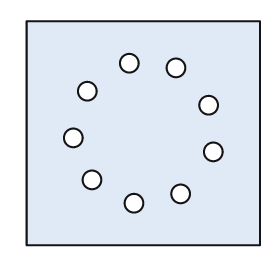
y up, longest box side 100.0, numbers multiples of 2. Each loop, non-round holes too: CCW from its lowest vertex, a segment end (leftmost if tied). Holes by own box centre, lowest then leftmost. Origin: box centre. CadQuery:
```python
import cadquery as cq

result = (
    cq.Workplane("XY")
    .moveTo(-50.0, -48.0)
    .lineTo(50.0, -48.0)
    .lineTo(50.0, 48.0)
    .lineTo(-50.0, 48.0)
    .close()
    .moveTo(-4.0, -30.0)
    .circle(4.0)
    .moveTo(16.0, -26.0)
    .circle(4.0)
    .moveTo(-22.0, -20.0)
    .circle(4.0)
    .moveTo(30.0, -8.0)
    .circle(4.0)
    .moveTo(-30.0, -2.0)
    .circle(4.0)
    .moveTo(28.0, 12.0)
    .circle(4.0)
    .moveTo(-24.0, 18.0)
    .circle(4.0)
    .moveTo(14.0, 28.0)
    .circle(4.0)
    .moveTo(-6.0, 30.0)
    .circle(4.0)
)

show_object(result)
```